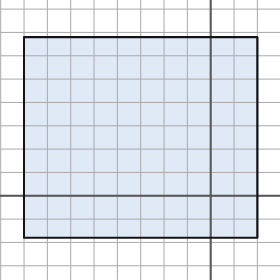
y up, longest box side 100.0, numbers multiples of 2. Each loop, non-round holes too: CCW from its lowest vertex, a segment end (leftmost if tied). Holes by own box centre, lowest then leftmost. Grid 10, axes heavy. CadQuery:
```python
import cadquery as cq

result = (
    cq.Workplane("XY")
    .moveTo(-80.0, -18.0)
    .lineTo(20.0, -18.0)
    .lineTo(20.0, 68.0)
    .lineTo(-80.0, 68.0)
    .close()
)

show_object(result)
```